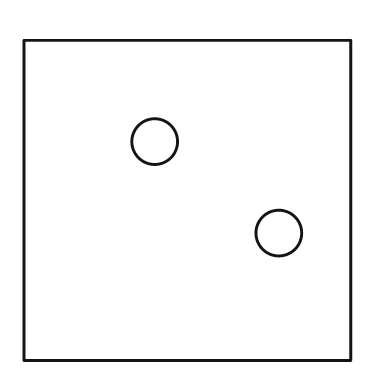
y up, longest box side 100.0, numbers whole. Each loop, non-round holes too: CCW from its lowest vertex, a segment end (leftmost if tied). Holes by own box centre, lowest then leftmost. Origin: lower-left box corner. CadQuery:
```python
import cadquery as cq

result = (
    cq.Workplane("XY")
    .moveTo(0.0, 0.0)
    .lineTo(100.0, 0.0)
    .lineTo(100.0, 98.0)
    .lineTo(0.0, 98.0)
    .close()
    .moveTo(78.0, 39.0)
    .circle(7.0)
    .moveTo(40.0, 67.0)
    .circle(7.0)
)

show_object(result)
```